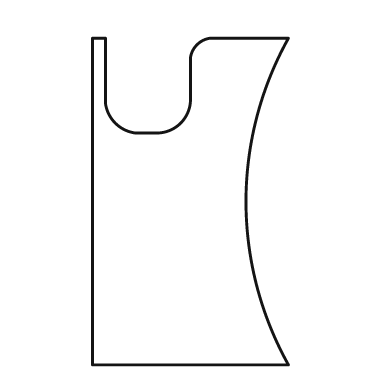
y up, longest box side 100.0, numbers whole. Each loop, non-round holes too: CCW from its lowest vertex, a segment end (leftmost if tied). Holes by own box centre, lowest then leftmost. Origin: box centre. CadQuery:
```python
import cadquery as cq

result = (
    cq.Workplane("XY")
    .moveTo(-30.0, -50.0)
    .lineTo(30.0, -50.0)
    .threePointArc((17.0, 0.0), (30.0, 50.0))
    .lineTo(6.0, 50.0)
    .threePointArc((2.0, 48.0), (0.0, 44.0))
    .lineTo(0.0, 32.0)
    .threePointArc((-3.0, 24.0), (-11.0, 21.0))
    .lineTo(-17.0, 21.0)
    .threePointArc((-23.0, 24.0), (-26.0, 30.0))
    .lineTo(-26.0, 50.0)
    .lineTo(-30.0, 50.0)
    .close()
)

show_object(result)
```